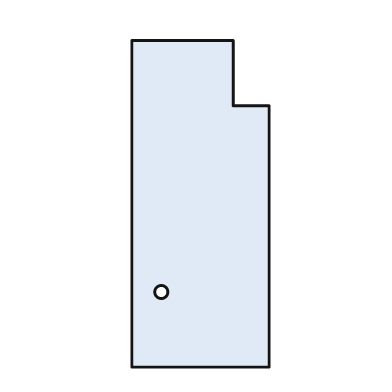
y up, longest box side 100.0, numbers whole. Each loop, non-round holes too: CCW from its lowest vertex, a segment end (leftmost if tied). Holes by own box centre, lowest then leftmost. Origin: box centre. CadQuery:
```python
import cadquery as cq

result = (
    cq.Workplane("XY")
    .moveTo(-21.0, -50.0)
    .lineTo(21.0, -50.0)
    .lineTo(21.0, 30.0)
    .lineTo(10.0, 30.0)
    .lineTo(10.0, 50.0)
    .lineTo(-21.0, 50.0)
    .close()
    .moveTo(-12.0, -27.0)
    .circle(2.0)
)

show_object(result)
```